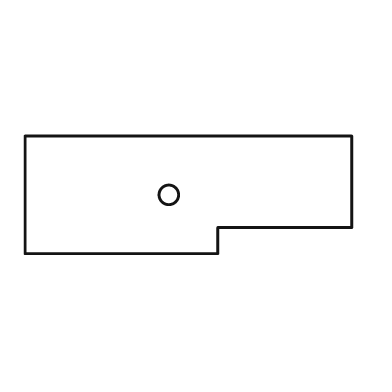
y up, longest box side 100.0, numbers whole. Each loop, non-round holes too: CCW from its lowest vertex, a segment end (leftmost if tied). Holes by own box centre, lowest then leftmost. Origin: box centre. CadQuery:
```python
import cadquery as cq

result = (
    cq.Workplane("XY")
    .moveTo(-50.0, -18.0)
    .lineTo(9.0, -18.0)
    .lineTo(9.0, -10.0)
    .lineTo(50.0, -10.0)
    .lineTo(50.0, 18.0)
    .lineTo(-50.0, 18.0)
    .close()
    .moveTo(-6.0, 0.0)
    .circle(3.0)
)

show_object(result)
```